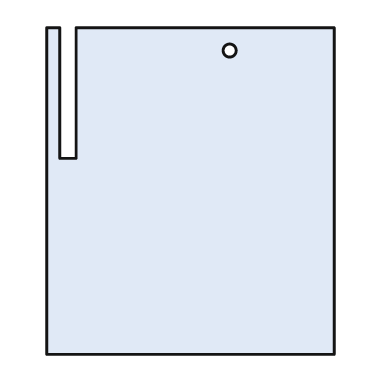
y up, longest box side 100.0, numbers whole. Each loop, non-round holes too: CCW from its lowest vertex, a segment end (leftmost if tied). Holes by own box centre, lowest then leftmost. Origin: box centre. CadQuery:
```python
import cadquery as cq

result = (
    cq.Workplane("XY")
    .moveTo(-44.0, -50.0)
    .lineTo(44.0, -50.0)
    .lineTo(44.0, 50.0)
    .lineTo(-35.0, 50.0)
    .lineTo(-35.0, 10.0)
    .lineTo(-40.0, 10.0)
    .lineTo(-40.0, 50.0)
    .lineTo(-44.0, 50.0)
    .close()
    .moveTo(12.0, 43.0)
    .circle(2.0)
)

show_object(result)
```